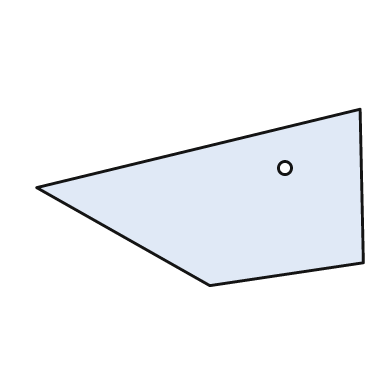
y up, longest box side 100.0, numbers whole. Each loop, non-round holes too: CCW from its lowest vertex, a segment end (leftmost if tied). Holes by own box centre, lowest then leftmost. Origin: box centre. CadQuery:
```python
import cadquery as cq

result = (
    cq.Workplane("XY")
    .moveTo(3.0, -27.0)
    .lineTo(50.0, -20.0)
    .lineTo(49.0, 27.0)
    .lineTo(-50.0, 3.0)
    .close()
    .moveTo(26.0, 9.0)
    .circle(2.0)
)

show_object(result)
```